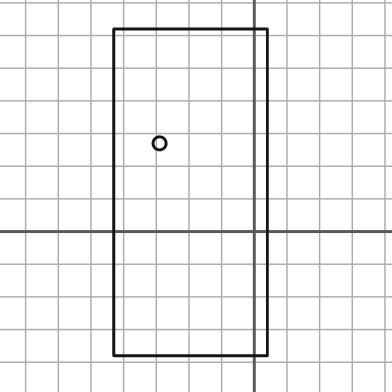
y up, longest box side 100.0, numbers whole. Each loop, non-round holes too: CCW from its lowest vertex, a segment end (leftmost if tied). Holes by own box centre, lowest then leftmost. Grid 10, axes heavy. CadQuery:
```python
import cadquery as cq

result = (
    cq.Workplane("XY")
    .moveTo(-43.0, -38.0)
    .lineTo(4.0, -38.0)
    .lineTo(4.0, 62.0)
    .lineTo(-43.0, 62.0)
    .close()
    .moveTo(-29.0, 27.0)
    .circle(2.0)
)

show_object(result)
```